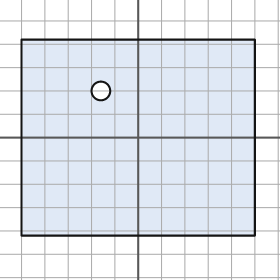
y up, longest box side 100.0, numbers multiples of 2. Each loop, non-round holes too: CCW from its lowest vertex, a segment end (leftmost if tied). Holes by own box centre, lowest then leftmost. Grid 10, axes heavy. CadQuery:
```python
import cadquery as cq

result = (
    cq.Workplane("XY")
    .moveTo(-50.0, -42.0)
    .lineTo(50.0, -42.0)
    .lineTo(50.0, 42.0)
    .lineTo(-50.0, 42.0)
    .close()
    .moveTo(-16.0, 20.0)
    .circle(4.0)
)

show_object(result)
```